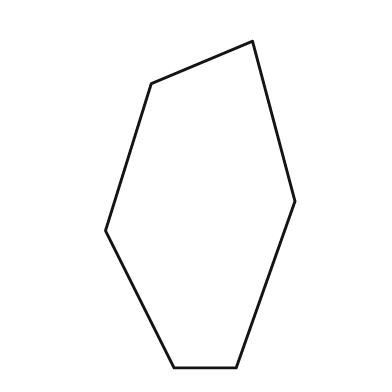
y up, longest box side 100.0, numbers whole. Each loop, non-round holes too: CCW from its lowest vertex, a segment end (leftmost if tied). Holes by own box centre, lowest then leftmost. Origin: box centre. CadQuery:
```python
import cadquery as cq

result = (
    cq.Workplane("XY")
    .moveTo(-8.0, -50.0)
    .lineTo(11.0, -50.0)
    .lineTo(29.0, 1.0)
    .lineTo(16.0, 50.0)
    .lineTo(-15.0, 37.0)
    .lineTo(-29.0, -8.0)
    .close()
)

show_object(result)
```